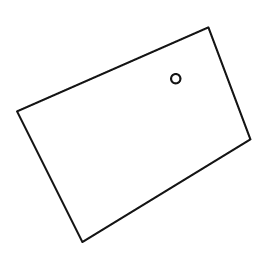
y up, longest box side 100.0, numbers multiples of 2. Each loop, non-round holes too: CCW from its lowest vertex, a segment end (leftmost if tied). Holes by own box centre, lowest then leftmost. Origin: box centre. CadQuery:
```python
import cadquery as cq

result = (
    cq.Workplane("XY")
    .moveTo(-22.0, -46.0)
    .lineTo(50.0, -2.0)
    .lineTo(32.0, 46.0)
    .lineTo(-50.0, 10.0)
    .close()
    .moveTo(18.0, 24.0)
    .circle(2.0)
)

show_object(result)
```